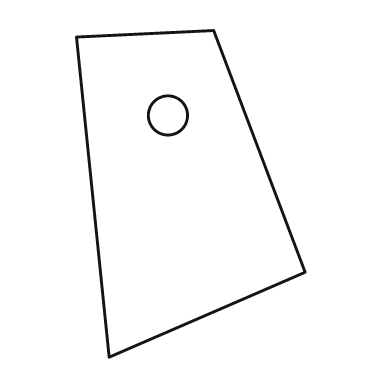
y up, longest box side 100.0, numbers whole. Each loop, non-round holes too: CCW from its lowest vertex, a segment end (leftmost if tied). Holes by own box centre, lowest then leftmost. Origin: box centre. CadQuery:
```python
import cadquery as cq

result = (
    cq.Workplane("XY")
    .moveTo(-25.0, -50.0)
    .lineTo(35.0, -24.0)
    .lineTo(7.0, 50.0)
    .lineTo(-35.0, 48.0)
    .close()
    .moveTo(-7.0, 24.0)
    .circle(6.0)
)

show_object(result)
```